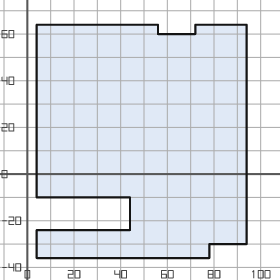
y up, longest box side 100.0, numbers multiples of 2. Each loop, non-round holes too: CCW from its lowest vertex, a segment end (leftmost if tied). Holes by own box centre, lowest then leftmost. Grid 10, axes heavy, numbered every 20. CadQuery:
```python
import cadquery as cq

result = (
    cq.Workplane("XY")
    .moveTo(4.0, -36.0)
    .lineTo(78.0, -36.0)
    .lineTo(78.0, -30.0)
    .lineTo(94.0, -30.0)
    .lineTo(94.0, 64.0)
    .lineTo(72.0, 64.0)
    .lineTo(72.0, 60.0)
    .lineTo(56.0, 60.0)
    .lineTo(56.0, 64.0)
    .lineTo(4.0, 64.0)
    .lineTo(4.0, -10.0)
    .lineTo(44.0, -10.0)
    .lineTo(44.0, -24.0)
    .lineTo(4.0, -24.0)
    .close()
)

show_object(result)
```